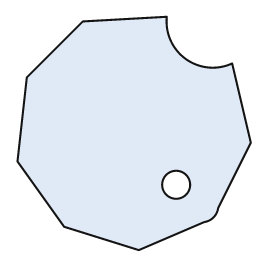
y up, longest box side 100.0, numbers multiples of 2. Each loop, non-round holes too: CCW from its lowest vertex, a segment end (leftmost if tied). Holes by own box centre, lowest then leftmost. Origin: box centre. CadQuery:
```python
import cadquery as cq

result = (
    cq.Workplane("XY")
    .moveTo(2.0, -50.0)
    .lineTo(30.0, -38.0)
    .threePointArc((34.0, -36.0), (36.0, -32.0))
    .lineTo(50.0, -4.0)
    .lineTo(42.0, 30.0)
    .threePointArc((22.0, 32.0), (14.0, 50.0))
    .lineTo(-22.0, 48.0)
    .lineTo(-46.0, 24.0)
    .lineTo(-50.0, -12.0)
    .lineTo(-30.0, -40.0)
    .close()
    .moveTo(18.0, -22.0)
    .circle(6.0)
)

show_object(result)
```